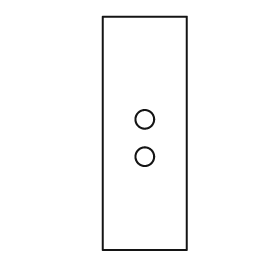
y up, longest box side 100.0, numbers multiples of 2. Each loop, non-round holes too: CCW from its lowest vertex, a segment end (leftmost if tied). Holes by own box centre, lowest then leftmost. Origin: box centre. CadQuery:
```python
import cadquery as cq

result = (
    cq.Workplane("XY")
    .moveTo(-18.0, -50.0)
    .lineTo(18.0, -50.0)
    .lineTo(18.0, 50.0)
    .lineTo(-18.0, 50.0)
    .close()
    .moveTo(0.0, -10.0)
    .circle(4.0)
    .moveTo(0.0, 6.0)
    .circle(4.0)
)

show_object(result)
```